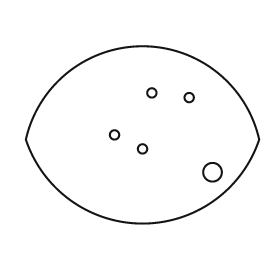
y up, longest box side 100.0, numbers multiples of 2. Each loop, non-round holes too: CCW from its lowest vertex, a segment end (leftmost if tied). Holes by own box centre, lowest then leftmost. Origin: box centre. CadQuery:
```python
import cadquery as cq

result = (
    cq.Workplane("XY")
    .moveTo(-50.0, -2.0)
    .threePointArc((0.0, -38.0), (50.0, -2.0))
    .threePointArc((0.0, 38.0), (-50.0, -2.0))
    .close()
    .moveTo(30.0, -16.0)
    .circle(4.0)
    .moveTo(0.0, -6.0)
    .circle(2.0)
    .moveTo(-12.0, 0.0)
    .circle(2.0)
    .moveTo(20.0, 16.0)
    .circle(2.0)
    .moveTo(4.0, 18.0)
    .circle(2.0)
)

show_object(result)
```